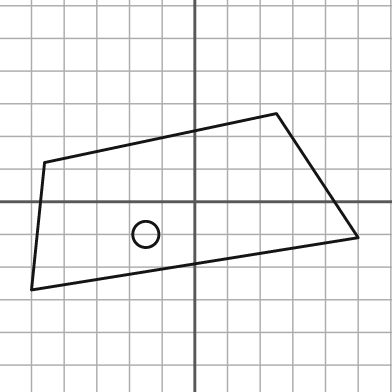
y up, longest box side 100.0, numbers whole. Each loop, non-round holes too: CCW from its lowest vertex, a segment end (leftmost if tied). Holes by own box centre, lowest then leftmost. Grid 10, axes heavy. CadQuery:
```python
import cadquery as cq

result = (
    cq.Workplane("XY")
    .moveTo(-50.0, -27.0)
    .lineTo(50.0, -11.0)
    .lineTo(25.0, 27.0)
    .lineTo(-46.0, 12.0)
    .close()
    .moveTo(-15.0, -10.0)
    .circle(4.0)
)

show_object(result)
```